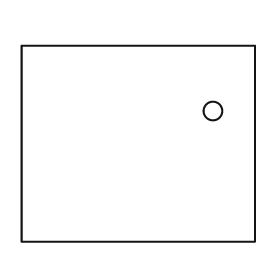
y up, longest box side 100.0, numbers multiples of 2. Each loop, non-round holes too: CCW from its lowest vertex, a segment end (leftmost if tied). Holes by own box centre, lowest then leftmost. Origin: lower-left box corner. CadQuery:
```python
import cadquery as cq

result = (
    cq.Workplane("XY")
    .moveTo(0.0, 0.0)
    .lineTo(100.0, 0.0)
    .lineTo(100.0, 84.0)
    .lineTo(0.0, 84.0)
    .close()
    .moveTo(82.0, 56.0)
    .circle(4.0)
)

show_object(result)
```